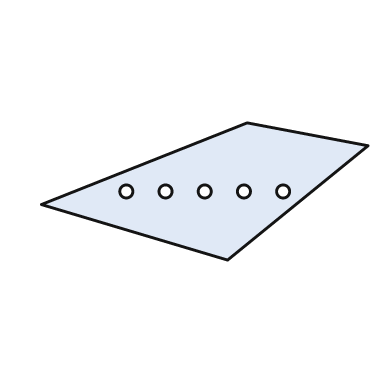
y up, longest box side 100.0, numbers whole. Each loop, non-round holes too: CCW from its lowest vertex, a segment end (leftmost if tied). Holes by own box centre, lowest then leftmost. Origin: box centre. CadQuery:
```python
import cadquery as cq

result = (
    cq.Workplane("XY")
    .moveTo(7.0, -21.0)
    .lineTo(50.0, 14.0)
    .lineTo(13.0, 21.0)
    .lineTo(-50.0, -4.0)
    .close()
    .moveTo(-24.0, 0.0)
    .circle(2.0)
    .moveTo(-12.0, 0.0)
    .circle(2.0)
    .moveTo(0.0, 0.0)
    .circle(2.0)
    .moveTo(12.0, 0.0)
    .circle(2.0)
    .moveTo(24.0, 0.0)
    .circle(2.0)
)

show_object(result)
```